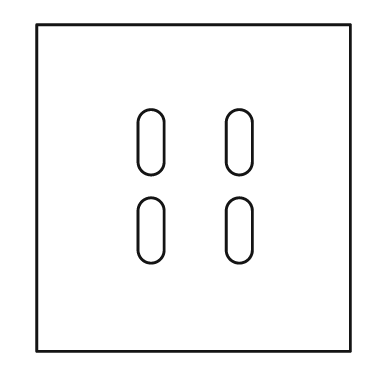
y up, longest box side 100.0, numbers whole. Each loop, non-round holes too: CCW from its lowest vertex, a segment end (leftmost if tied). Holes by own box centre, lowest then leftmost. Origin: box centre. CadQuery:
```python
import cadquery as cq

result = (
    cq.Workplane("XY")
    .moveTo(-48.0, -50.0)
    .lineTo(48.0, -50.0)
    .lineTo(48.0, 50.0)
    .lineTo(-48.0, 50.0)
    .close()
    .moveTo(-17.0, -19.0)
    .threePointArc((-13.0, -23.0), (-9.0, -19.0))
    .lineTo(-9.0, -7.0)
    .threePointArc((-13.0, -3.0), (-17.0, -7.0))
    .close()
    .moveTo(10.0, -19.0)
    .threePointArc((14.0, -23.0), (18.0, -19.0))
    .lineTo(18.0, -7.0)
    .threePointArc((14.0, -3.0), (10.0, -7.0))
    .close()
    .moveTo(-17.0, 8.0)
    .threePointArc((-13.0, 4.0), (-9.0, 8.0))
    .lineTo(-9.0, 20.0)
    .threePointArc((-13.0, 24.0), (-17.0, 20.0))
    .close()
    .moveTo(10.0, 8.0)
    .threePointArc((14.0, 4.0), (18.0, 8.0))
    .lineTo(18.0, 20.0)
    .threePointArc((14.0, 24.0), (10.0, 20.0))
    .close()
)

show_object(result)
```